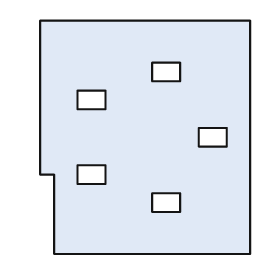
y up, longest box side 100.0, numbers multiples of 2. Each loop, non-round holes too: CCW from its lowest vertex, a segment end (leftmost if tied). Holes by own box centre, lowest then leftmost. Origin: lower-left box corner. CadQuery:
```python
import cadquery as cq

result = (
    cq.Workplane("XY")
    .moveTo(6.0, 0.0)
    .lineTo(90.0, 0.0)
    .lineTo(90.0, 100.0)
    .lineTo(0.0, 100.0)
    .lineTo(0.0, 34.0)
    .lineTo(6.0, 34.0)
    .close()
    .moveTo(48.0, 18.0)
    .lineTo(60.0, 18.0)
    .lineTo(60.0, 26.0)
    .lineTo(48.0, 26.0)
    .close()
    .moveTo(16.0, 30.0)
    .lineTo(28.0, 30.0)
    .lineTo(28.0, 38.0)
    .lineTo(16.0, 38.0)
    .close()
    .moveTo(68.0, 46.0)
    .lineTo(80.0, 46.0)
    .lineTo(80.0, 54.0)
    .lineTo(68.0, 54.0)
    .close()
    .moveTo(16.0, 62.0)
    .lineTo(28.0, 62.0)
    .lineTo(28.0, 70.0)
    .lineTo(16.0, 70.0)
    .close()
    .moveTo(48.0, 74.0)
    .lineTo(60.0, 74.0)
    .lineTo(60.0, 82.0)
    .lineTo(48.0, 82.0)
    .close()
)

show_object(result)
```